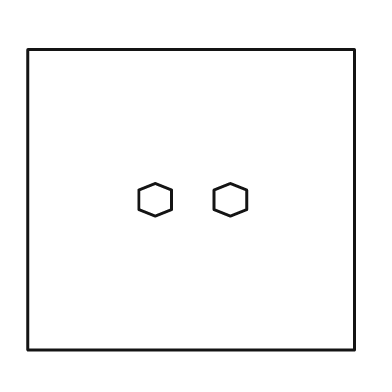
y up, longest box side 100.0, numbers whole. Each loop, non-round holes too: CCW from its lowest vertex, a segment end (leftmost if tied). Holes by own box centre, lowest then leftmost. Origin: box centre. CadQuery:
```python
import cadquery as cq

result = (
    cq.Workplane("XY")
    .moveTo(-50.0, -46.0)
    .lineTo(50.0, -46.0)
    .lineTo(50.0, 46.0)
    .lineTo(-50.0, 46.0)
    .close()
    .moveTo(-11.0, -5.0)
    .lineTo(-6.0, -3.0)
    .lineTo(-6.0, 3.0)
    .lineTo(-11.0, 5.0)
    .lineTo(-16.0, 3.0)
    .lineTo(-16.0, -3.0)
    .close()
    .moveTo(12.0, -5.0)
    .lineTo(17.0, -3.0)
    .lineTo(17.0, 3.0)
    .lineTo(12.0, 5.0)
    .lineTo(7.0, 3.0)
    .lineTo(7.0, -3.0)
    .close()
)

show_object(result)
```